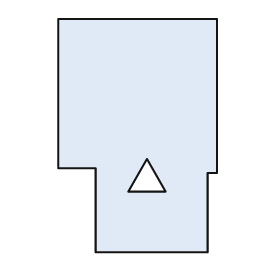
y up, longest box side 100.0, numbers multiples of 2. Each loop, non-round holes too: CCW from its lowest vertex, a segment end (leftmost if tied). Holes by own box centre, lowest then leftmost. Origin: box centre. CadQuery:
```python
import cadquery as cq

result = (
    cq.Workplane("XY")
    .moveTo(-18.0, -50.0)
    .lineTo(30.0, -50.0)
    .lineTo(30.0, -16.0)
    .lineTo(34.0, -16.0)
    .lineTo(34.0, 50.0)
    .lineTo(-34.0, 50.0)
    .lineTo(-34.0, -14.0)
    .lineTo(-18.0, -14.0)
    .close()
    .moveTo(-4.0, -24.0)
    .lineTo(12.0, -24.0)
    .lineTo(4.0, -10.0)
    .close()
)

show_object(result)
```